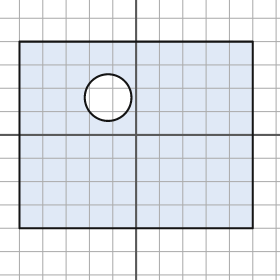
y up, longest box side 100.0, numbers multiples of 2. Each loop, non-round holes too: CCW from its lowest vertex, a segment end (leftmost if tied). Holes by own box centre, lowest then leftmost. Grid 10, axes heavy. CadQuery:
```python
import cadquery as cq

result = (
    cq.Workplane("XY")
    .moveTo(-50.0, -40.0)
    .lineTo(50.0, -40.0)
    .lineTo(50.0, 40.0)
    .lineTo(-50.0, 40.0)
    .close()
    .moveTo(-12.0, 16.0)
    .circle(10.0)
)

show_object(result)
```